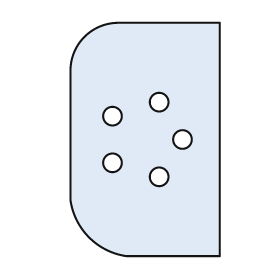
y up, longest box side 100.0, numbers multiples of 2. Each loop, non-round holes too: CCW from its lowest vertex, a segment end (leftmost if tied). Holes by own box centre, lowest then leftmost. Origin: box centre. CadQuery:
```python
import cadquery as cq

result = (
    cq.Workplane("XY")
    .moveTo(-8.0, -50.0)
    .lineTo(32.0, -50.0)
    .lineTo(32.0, 50.0)
    .lineTo(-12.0, 50.0)
    .threePointArc((-26.0, 44.0), (-32.0, 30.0))
    .lineTo(-32.0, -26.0)
    .threePointArc((-24.0, -42.0), (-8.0, -50.0))
    .close()
    .moveTo(6.0, -16.0)
    .circle(4.0)
    .moveTo(-14.0, -10.0)
    .circle(4.0)
    .moveTo(16.0, 0.0)
    .circle(4.0)
    .moveTo(-14.0, 10.0)
    .circle(4.0)
    .moveTo(6.0, 16.0)
    .circle(4.0)
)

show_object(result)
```